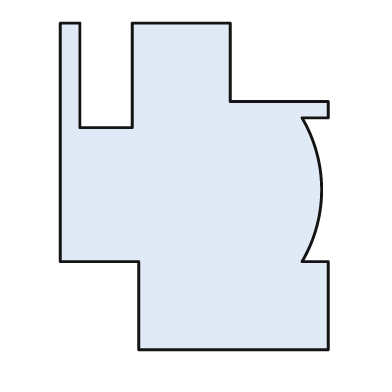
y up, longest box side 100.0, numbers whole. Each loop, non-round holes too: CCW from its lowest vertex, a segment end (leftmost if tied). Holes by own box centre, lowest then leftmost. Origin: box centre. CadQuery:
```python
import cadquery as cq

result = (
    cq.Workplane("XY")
    .moveTo(-17.0, -50.0)
    .lineTo(41.0, -50.0)
    .lineTo(41.0, -23.0)
    .lineTo(33.0, -23.0)
    .threePointArc((39.0, -1.0), (33.0, 21.0))
    .lineTo(41.0, 21.0)
    .lineTo(41.0, 26.0)
    .lineTo(11.0, 26.0)
    .lineTo(11.0, 50.0)
    .lineTo(-19.0, 50.0)
    .lineTo(-19.0, 18.0)
    .lineTo(-35.0, 18.0)
    .lineTo(-35.0, 50.0)
    .lineTo(-41.0, 50.0)
    .lineTo(-41.0, -23.0)
    .lineTo(-17.0, -23.0)
    .close()
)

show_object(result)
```